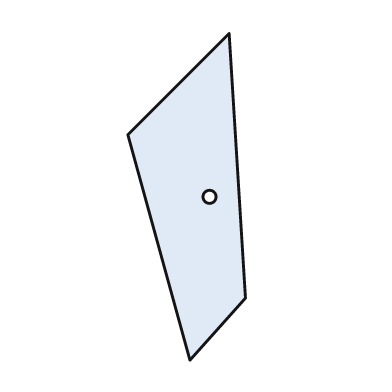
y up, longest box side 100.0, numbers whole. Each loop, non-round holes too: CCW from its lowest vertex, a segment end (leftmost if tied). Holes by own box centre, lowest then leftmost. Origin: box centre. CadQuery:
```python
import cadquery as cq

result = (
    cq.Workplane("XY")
    .moveTo(1.0, -50.0)
    .lineTo(18.0, -31.0)
    .lineTo(13.0, 50.0)
    .lineTo(-18.0, 19.0)
    .close()
    .moveTo(7.0, 0.0)
    .circle(2.0)
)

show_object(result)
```